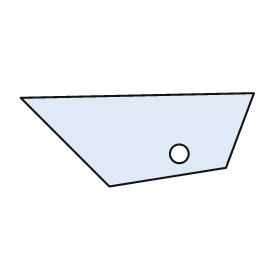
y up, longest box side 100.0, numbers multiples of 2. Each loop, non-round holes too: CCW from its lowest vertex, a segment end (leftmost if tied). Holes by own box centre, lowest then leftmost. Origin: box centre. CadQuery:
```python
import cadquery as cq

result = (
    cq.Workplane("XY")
    .moveTo(-12.0, -20.0)
    .lineTo(38.0, -12.0)
    .lineTo(50.0, 20.0)
    .lineTo(-50.0, 18.0)
    .close()
    .moveTo(18.0, -6.0)
    .circle(4.0)
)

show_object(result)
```